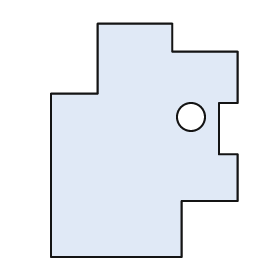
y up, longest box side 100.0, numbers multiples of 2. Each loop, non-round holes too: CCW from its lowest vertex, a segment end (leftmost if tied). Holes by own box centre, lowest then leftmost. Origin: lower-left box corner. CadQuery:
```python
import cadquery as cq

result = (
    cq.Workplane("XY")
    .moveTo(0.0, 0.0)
    .lineTo(56.0, 0.0)
    .lineTo(56.0, 24.0)
    .lineTo(80.0, 24.0)
    .lineTo(80.0, 44.0)
    .lineTo(72.0, 44.0)
    .lineTo(72.0, 66.0)
    .lineTo(80.0, 66.0)
    .lineTo(80.0, 88.0)
    .lineTo(52.0, 88.0)
    .lineTo(52.0, 100.0)
    .lineTo(20.0, 100.0)
    .lineTo(20.0, 70.0)
    .lineTo(0.0, 70.0)
    .close()
    .moveTo(60.0, 60.0)
    .circle(6.0)
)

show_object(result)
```